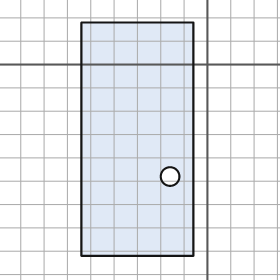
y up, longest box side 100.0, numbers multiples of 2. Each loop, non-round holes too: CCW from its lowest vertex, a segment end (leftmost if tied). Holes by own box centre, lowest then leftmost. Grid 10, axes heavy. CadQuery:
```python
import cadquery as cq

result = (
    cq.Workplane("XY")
    .moveTo(-54.0, -82.0)
    .lineTo(-6.0, -82.0)
    .lineTo(-6.0, 18.0)
    .lineTo(-54.0, 18.0)
    .close()
    .moveTo(-16.0, -48.0)
    .circle(4.0)
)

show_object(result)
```